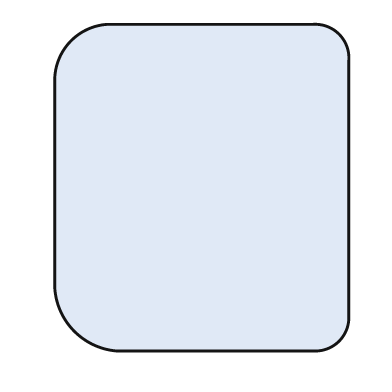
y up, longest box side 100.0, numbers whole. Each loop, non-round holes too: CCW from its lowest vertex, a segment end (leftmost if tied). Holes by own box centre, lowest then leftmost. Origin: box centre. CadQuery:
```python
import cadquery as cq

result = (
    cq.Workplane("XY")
    .moveTo(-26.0, -50.0)
    .lineTo(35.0, -50.0)
    .threePointArc((42.0, -47.0), (45.0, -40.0))
    .lineTo(45.0, 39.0)
    .threePointArc((42.0, 47.0), (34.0, 50.0))
    .lineTo(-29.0, 50.0)
    .threePointArc((-40.0, 45.0), (-45.0, 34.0))
    .lineTo(-45.0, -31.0)
    .threePointArc((-39.0, -44.0), (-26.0, -50.0))
    .close()
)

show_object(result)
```